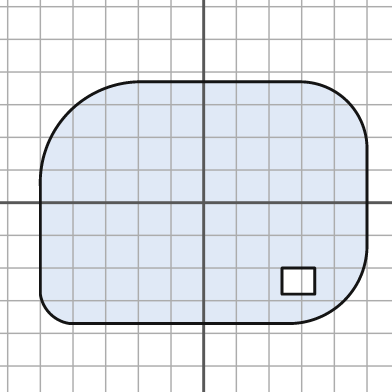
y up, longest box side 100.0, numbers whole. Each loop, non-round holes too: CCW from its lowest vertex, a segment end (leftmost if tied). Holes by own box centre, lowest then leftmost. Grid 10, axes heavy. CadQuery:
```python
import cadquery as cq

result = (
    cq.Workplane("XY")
    .moveTo(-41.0, -37.0)
    .lineTo(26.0, -37.0)
    .threePointArc((43.0, -30.0), (50.0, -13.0))
    .lineTo(50.0, 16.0)
    .threePointArc((44.0, 31.0), (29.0, 37.0))
    .lineTo(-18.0, 37.0)
    .threePointArc((-41.0, 28.0), (-50.0, 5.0))
    .lineTo(-50.0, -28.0)
    .threePointArc((-47.0, -34.0), (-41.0, -37.0))
    .close()
    .moveTo(24.0, -28.0)
    .lineTo(34.0, -28.0)
    .lineTo(34.0, -20.0)
    .lineTo(24.0, -20.0)
    .close()
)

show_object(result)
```